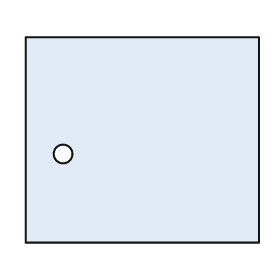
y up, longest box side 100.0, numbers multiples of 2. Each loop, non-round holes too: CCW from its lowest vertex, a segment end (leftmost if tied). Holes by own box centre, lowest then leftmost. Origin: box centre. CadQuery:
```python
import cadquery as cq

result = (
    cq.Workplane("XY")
    .moveTo(-50.0, -44.0)
    .lineTo(50.0, -44.0)
    .lineTo(50.0, 44.0)
    .lineTo(-50.0, 44.0)
    .close()
    .moveTo(-34.0, -6.0)
    .circle(4.0)
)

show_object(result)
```